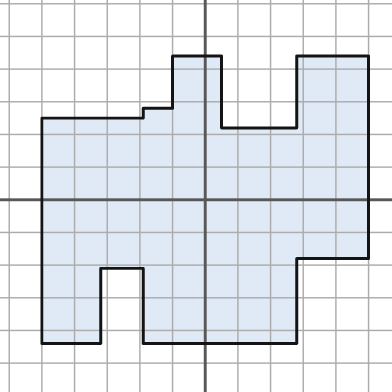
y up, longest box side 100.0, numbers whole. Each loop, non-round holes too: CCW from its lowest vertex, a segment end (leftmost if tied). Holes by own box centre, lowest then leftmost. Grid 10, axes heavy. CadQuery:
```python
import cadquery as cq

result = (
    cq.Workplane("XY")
    .moveTo(-50.0, -44.0)
    .lineTo(-32.0, -44.0)
    .lineTo(-32.0, -21.0)
    .lineTo(-19.0, -21.0)
    .lineTo(-19.0, -44.0)
    .lineTo(28.0, -44.0)
    .lineTo(28.0, -18.0)
    .lineTo(50.0, -18.0)
    .lineTo(50.0, 44.0)
    .lineTo(28.0, 44.0)
    .lineTo(28.0, 22.0)
    .lineTo(5.0, 22.0)
    .lineTo(5.0, 44.0)
    .lineTo(-10.0, 44.0)
    .lineTo(-10.0, 28.0)
    .lineTo(-19.0, 28.0)
    .lineTo(-19.0, 25.0)
    .lineTo(-50.0, 25.0)
    .close()
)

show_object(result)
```